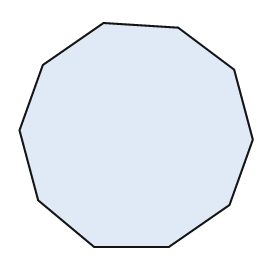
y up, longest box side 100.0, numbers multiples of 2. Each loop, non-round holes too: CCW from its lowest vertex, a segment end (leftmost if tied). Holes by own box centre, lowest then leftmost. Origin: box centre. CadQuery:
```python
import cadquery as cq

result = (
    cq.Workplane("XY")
    .moveTo(-18.0, -48.0)
    .lineTo(14.0, -48.0)
    .lineTo(40.0, -30.0)
    .lineTo(50.0, -2.0)
    .lineTo(42.0, 28.0)
    .lineTo(18.0, 46.0)
    .lineTo(-14.0, 48.0)
    .lineTo(-40.0, 30.0)
    .lineTo(-50.0, 2.0)
    .lineTo(-42.0, -28.0)
    .close()
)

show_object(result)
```